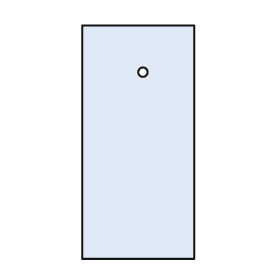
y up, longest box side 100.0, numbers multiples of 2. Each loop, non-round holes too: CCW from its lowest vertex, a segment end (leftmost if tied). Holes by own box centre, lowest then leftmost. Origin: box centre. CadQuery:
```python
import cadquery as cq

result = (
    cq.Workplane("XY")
    .moveTo(-24.0, -50.0)
    .lineTo(24.0, -50.0)
    .lineTo(24.0, 50.0)
    .lineTo(-24.0, 50.0)
    .close()
    .moveTo(2.0, 30.0)
    .circle(2.0)
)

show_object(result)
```